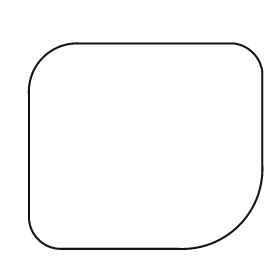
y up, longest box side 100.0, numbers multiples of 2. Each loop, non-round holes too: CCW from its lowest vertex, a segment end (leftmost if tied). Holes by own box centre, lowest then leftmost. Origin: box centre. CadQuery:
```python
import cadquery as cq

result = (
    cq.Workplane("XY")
    .moveTo(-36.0, -44.0)
    .lineTo(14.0, -44.0)
    .threePointArc((40.0, -34.0), (50.0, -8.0))
    .lineTo(50.0, 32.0)
    .threePointArc((46.0, 40.0), (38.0, 44.0))
    .lineTo(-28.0, 44.0)
    .threePointArc((-44.0, 38.0), (-50.0, 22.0))
    .lineTo(-50.0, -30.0)
    .threePointArc((-46.0, -40.0), (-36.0, -44.0))
    .close()
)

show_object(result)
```